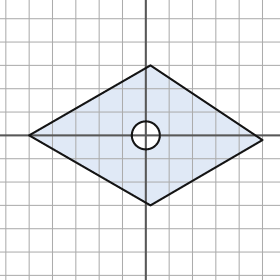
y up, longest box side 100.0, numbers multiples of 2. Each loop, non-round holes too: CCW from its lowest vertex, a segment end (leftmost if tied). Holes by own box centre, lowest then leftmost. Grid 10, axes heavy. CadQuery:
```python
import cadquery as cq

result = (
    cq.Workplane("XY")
    .moveTo(2.0, -30.0)
    .lineTo(50.0, -2.0)
    .lineTo(2.0, 30.0)
    .lineTo(-50.0, 0.0)
    .close()
    .moveTo(0.0, 0.0)
    .circle(6.0)
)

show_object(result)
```